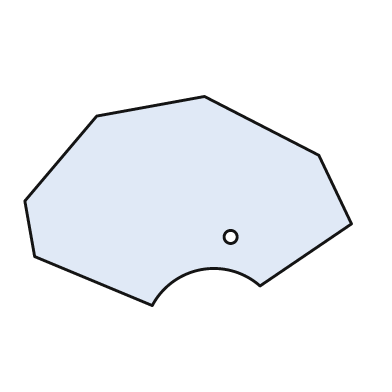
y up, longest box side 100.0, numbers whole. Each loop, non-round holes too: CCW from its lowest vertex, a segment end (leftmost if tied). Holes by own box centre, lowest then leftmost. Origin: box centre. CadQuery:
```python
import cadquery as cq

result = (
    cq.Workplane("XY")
    .moveTo(-11.0, -32.0)
    .threePointArc((4.0, -21.0), (22.0, -26.0))
    .lineTo(50.0, -7.0)
    .lineTo(40.0, 14.0)
    .lineTo(5.0, 32.0)
    .lineTo(-28.0, 26.0)
    .lineTo(-50.0, 0.0)
    .lineTo(-47.0, -17.0)
    .close()
    .moveTo(13.0, -11.0)
    .circle(2.0)
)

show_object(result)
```